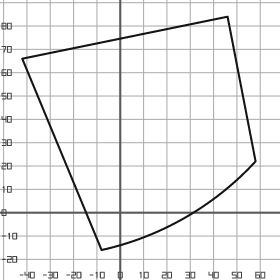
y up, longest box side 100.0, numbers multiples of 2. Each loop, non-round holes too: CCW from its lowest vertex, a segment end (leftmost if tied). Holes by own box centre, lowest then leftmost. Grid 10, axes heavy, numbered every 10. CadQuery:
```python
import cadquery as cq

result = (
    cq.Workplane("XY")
    .moveTo(-8.0, -16.0)
    .threePointArc((28.0, -2.0), (58.0, 22.0))
    .lineTo(46.0, 84.0)
    .lineTo(-42.0, 66.0)
    .close()
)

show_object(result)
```